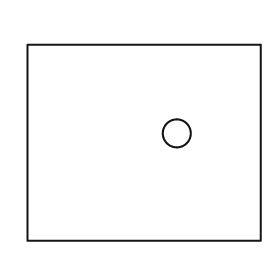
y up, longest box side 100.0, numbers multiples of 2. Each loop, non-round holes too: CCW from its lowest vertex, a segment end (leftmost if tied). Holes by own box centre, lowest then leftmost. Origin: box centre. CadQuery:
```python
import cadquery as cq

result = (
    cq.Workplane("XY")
    .moveTo(-50.0, -42.0)
    .lineTo(50.0, -42.0)
    .lineTo(50.0, 42.0)
    .lineTo(-50.0, 42.0)
    .close()
    .moveTo(14.0, 4.0)
    .circle(6.0)
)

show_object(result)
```